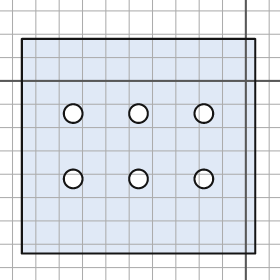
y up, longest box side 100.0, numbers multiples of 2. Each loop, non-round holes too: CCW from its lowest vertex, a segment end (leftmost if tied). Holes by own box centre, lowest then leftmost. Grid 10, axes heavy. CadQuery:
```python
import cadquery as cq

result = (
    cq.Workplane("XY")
    .moveTo(-96.0, -74.0)
    .lineTo(4.0, -74.0)
    .lineTo(4.0, 18.0)
    .lineTo(-96.0, 18.0)
    .close()
    .moveTo(-74.0, -42.0)
    .circle(4.0)
    .moveTo(-46.0, -42.0)
    .circle(4.0)
    .moveTo(-18.0, -42.0)
    .circle(4.0)
    .moveTo(-74.0, -14.0)
    .circle(4.0)
    .moveTo(-46.0, -14.0)
    .circle(4.0)
    .moveTo(-18.0, -14.0)
    .circle(4.0)
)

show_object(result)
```